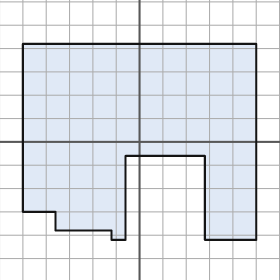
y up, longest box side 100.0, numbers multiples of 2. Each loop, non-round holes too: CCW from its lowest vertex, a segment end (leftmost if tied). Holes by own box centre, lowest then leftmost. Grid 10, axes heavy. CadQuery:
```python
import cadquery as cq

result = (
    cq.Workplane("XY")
    .moveTo(-12.0, -42.0)
    .lineTo(-6.0, -42.0)
    .lineTo(-6.0, -6.0)
    .lineTo(28.0, -6.0)
    .lineTo(28.0, -42.0)
    .lineTo(50.0, -42.0)
    .lineTo(50.0, 42.0)
    .lineTo(-50.0, 42.0)
    .lineTo(-50.0, -30.0)
    .lineTo(-36.0, -30.0)
    .lineTo(-36.0, -38.0)
    .lineTo(-12.0, -38.0)
    .close()
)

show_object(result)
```